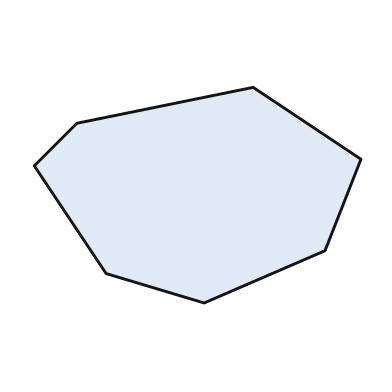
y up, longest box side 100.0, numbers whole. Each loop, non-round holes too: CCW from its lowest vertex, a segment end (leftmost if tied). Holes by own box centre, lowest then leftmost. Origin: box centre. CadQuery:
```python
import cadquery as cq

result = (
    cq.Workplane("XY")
    .moveTo(2.0, -33.0)
    .lineTo(39.0, -17.0)
    .lineTo(50.0, 11.0)
    .lineTo(17.0, 33.0)
    .lineTo(-37.0, 22.0)
    .lineTo(-50.0, 9.0)
    .lineTo(-28.0, -24.0)
    .close()
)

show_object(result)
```